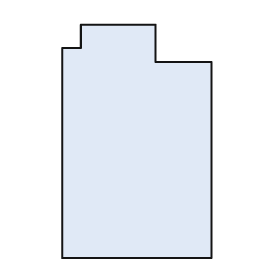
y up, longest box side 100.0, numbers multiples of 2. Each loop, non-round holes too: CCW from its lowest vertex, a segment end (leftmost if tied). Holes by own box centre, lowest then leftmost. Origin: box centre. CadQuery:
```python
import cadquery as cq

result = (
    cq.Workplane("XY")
    .moveTo(-32.0, -50.0)
    .lineTo(32.0, -50.0)
    .lineTo(32.0, 34.0)
    .lineTo(8.0, 34.0)
    .lineTo(8.0, 50.0)
    .lineTo(-24.0, 50.0)
    .lineTo(-24.0, 40.0)
    .lineTo(-32.0, 40.0)
    .close()
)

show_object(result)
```